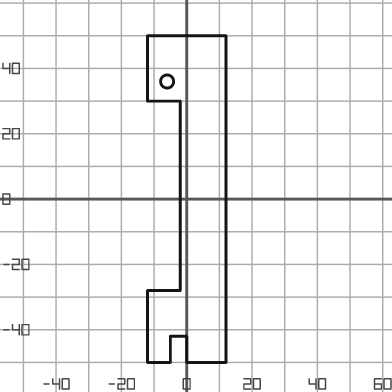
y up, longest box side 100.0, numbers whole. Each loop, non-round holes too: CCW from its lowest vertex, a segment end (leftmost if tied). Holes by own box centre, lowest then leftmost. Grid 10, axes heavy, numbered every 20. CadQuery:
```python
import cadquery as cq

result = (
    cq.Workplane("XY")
    .moveTo(-12.0, -50.0)
    .lineTo(-5.0, -50.0)
    .lineTo(-5.0, -42.0)
    .lineTo(0.0, -42.0)
    .lineTo(0.0, -50.0)
    .lineTo(12.0, -50.0)
    .lineTo(12.0, 50.0)
    .lineTo(-12.0, 50.0)
    .lineTo(-12.0, 30.0)
    .lineTo(-2.0, 30.0)
    .lineTo(-2.0, -28.0)
    .lineTo(-12.0, -28.0)
    .close()
    .moveTo(-6.0, 36.0)
    .circle(2.0)
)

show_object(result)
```